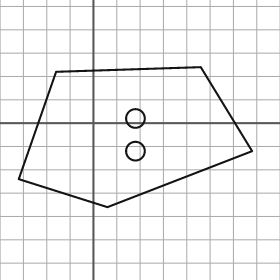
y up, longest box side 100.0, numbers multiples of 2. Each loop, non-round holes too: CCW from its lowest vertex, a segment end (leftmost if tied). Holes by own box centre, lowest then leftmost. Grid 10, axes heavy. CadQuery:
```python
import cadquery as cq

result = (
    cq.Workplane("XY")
    .moveTo(6.0, -36.0)
    .lineTo(68.0, -12.0)
    .lineTo(46.0, 24.0)
    .lineTo(-16.0, 22.0)
    .lineTo(-32.0, -24.0)
    .close()
    .moveTo(18.0, -12.0)
    .circle(4.0)
    .moveTo(18.0, 2.0)
    .circle(4.0)
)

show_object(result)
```